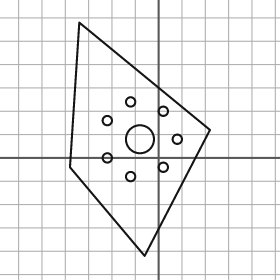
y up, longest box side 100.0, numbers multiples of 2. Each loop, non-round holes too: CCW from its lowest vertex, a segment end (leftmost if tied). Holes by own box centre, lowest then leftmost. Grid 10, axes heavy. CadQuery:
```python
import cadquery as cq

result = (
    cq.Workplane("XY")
    .moveTo(-6.0, -42.0)
    .lineTo(22.0, 12.0)
    .lineTo(-34.0, 58.0)
    .lineTo(-38.0, -4.0)
    .close()
    .moveTo(-12.0, -8.0)
    .circle(2.0)
    .moveTo(2.0, -4.0)
    .circle(2.0)
    .moveTo(-22.0, 0.0)
    .circle(2.0)
    .moveTo(-8.0, 8.0)
    .circle(6.0)
    .moveTo(8.0, 8.0)
    .circle(2.0)
    .moveTo(-22.0, 16.0)
    .circle(2.0)
    .moveTo(2.0, 20.0)
    .circle(2.0)
    .moveTo(-12.0, 24.0)
    .circle(2.0)
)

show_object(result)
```